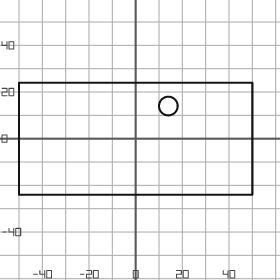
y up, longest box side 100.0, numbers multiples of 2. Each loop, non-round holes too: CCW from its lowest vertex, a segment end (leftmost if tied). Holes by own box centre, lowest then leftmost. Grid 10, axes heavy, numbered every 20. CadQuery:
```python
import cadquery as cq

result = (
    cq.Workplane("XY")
    .moveTo(-50.0, -24.0)
    .lineTo(50.0, -24.0)
    .lineTo(50.0, 24.0)
    .lineTo(-50.0, 24.0)
    .close()
    .moveTo(14.0, 14.0)
    .circle(4.0)
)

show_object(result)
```